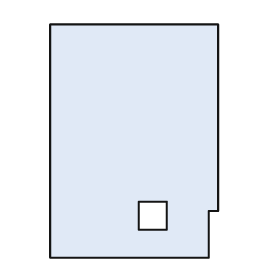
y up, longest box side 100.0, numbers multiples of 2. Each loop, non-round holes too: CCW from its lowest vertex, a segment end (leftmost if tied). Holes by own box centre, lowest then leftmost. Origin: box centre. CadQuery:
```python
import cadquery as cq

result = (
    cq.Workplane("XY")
    .moveTo(-36.0, -50.0)
    .lineTo(32.0, -50.0)
    .lineTo(32.0, -30.0)
    .lineTo(36.0, -30.0)
    .lineTo(36.0, 50.0)
    .lineTo(-36.0, 50.0)
    .close()
    .moveTo(2.0, -38.0)
    .lineTo(14.0, -38.0)
    .lineTo(14.0, -26.0)
    .lineTo(2.0, -26.0)
    .close()
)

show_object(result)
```